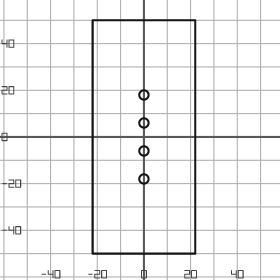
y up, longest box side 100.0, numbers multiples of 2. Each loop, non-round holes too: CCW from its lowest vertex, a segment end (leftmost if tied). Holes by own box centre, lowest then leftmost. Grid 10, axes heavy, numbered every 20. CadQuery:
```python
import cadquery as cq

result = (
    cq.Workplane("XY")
    .moveTo(-22.0, -50.0)
    .lineTo(22.0, -50.0)
    .lineTo(22.0, 50.0)
    .lineTo(-22.0, 50.0)
    .close()
    .moveTo(0.0, -18.0)
    .circle(2.0)
    .moveTo(0.0, -6.0)
    .circle(2.0)
    .moveTo(0.0, 6.0)
    .circle(2.0)
    .moveTo(0.0, 18.0)
    .circle(2.0)
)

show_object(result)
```